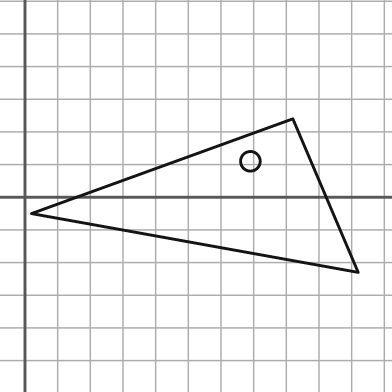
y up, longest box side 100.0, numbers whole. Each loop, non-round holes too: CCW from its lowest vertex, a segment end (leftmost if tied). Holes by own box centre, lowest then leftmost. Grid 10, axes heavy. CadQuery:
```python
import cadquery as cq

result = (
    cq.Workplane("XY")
    .moveTo(102.0, -23.0)
    .lineTo(82.0, 24.0)
    .lineTo(2.0, -5.0)
    .close()
    .moveTo(69.0, 11.0)
    .circle(3.0)
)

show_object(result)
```